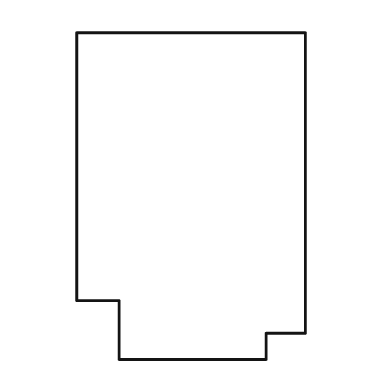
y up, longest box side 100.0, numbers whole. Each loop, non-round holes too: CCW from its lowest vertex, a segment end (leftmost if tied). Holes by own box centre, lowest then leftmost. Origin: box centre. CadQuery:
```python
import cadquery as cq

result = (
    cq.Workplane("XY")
    .moveTo(-22.0, -50.0)
    .lineTo(23.0, -50.0)
    .lineTo(23.0, -42.0)
    .lineTo(35.0, -42.0)
    .lineTo(35.0, 50.0)
    .lineTo(-35.0, 50.0)
    .lineTo(-35.0, -32.0)
    .lineTo(-22.0, -32.0)
    .close()
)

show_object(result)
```